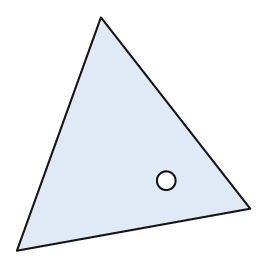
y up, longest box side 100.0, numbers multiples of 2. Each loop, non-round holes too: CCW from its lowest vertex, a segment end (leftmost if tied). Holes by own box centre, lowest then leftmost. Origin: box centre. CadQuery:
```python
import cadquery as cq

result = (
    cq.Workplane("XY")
    .moveTo(-50.0, -50.0)
    .lineTo(50.0, -32.0)
    .lineTo(-14.0, 50.0)
    .close()
    .moveTo(14.0, -20.0)
    .circle(4.0)
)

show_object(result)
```